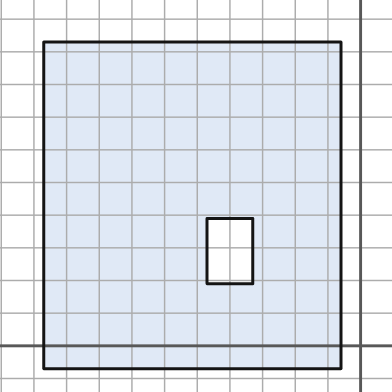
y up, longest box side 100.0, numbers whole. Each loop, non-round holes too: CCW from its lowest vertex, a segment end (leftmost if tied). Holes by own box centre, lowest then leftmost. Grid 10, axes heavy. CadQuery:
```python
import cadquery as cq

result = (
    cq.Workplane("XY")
    .moveTo(-97.0, -7.0)
    .lineTo(-6.0, -7.0)
    .lineTo(-6.0, 93.0)
    .lineTo(-97.0, 93.0)
    .close()
    .moveTo(-47.0, 19.0)
    .lineTo(-33.0, 19.0)
    .lineTo(-33.0, 39.0)
    .lineTo(-47.0, 39.0)
    .close()
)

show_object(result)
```